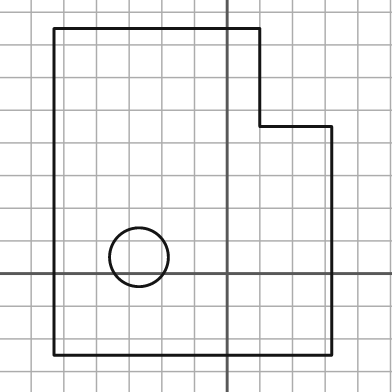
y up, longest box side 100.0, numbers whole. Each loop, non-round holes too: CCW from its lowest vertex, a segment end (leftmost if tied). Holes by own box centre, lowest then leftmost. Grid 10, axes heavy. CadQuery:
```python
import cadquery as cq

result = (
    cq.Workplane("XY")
    .moveTo(-53.0, -25.0)
    .lineTo(32.0, -25.0)
    .lineTo(32.0, 45.0)
    .lineTo(10.0, 45.0)
    .lineTo(10.0, 75.0)
    .lineTo(-53.0, 75.0)
    .close()
    .moveTo(-27.0, 5.0)
    .circle(9.0)
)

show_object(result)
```